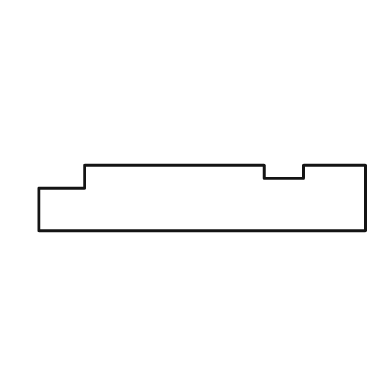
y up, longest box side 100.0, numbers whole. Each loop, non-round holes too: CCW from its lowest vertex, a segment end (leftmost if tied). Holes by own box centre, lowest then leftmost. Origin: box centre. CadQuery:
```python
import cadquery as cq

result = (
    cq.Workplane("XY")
    .moveTo(-50.0, -10.0)
    .lineTo(50.0, -10.0)
    .lineTo(50.0, 10.0)
    .lineTo(31.0, 10.0)
    .lineTo(31.0, 6.0)
    .lineTo(19.0, 6.0)
    .lineTo(19.0, 10.0)
    .lineTo(-36.0, 10.0)
    .lineTo(-36.0, 3.0)
    .lineTo(-50.0, 3.0)
    .close()
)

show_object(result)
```